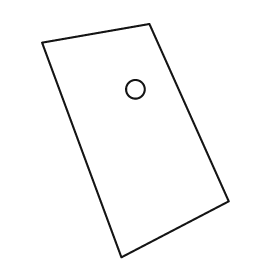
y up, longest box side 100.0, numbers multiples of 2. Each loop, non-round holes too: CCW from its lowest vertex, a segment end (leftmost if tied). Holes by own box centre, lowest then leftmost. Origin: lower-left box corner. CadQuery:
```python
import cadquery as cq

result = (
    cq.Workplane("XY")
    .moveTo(34.0, 0.0)
    .lineTo(80.0, 24.0)
    .lineTo(46.0, 100.0)
    .lineTo(0.0, 92.0)
    .close()
    .moveTo(40.0, 72.0)
    .circle(4.0)
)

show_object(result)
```